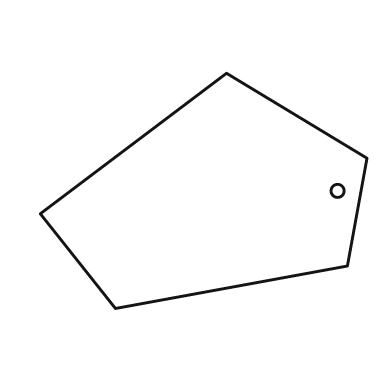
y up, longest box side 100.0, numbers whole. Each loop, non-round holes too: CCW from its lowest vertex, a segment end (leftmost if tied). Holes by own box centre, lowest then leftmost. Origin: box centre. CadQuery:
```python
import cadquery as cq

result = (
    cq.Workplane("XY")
    .moveTo(-27.0, -36.0)
    .lineTo(44.0, -23.0)
    .lineTo(50.0, 10.0)
    .lineTo(7.0, 36.0)
    .lineTo(-50.0, -7.0)
    .close()
    .moveTo(41.0, 0.0)
    .circle(2.0)
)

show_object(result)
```